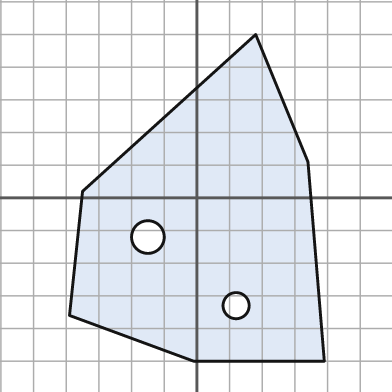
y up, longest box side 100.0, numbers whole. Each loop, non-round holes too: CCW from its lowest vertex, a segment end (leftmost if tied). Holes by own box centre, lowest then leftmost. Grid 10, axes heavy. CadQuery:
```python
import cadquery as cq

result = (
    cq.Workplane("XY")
    .moveTo(-1.0, -50.0)
    .lineTo(39.0, -50.0)
    .lineTo(34.0, 11.0)
    .lineTo(18.0, 50.0)
    .lineTo(-35.0, 2.0)
    .lineTo(-39.0, -36.0)
    .close()
    .moveTo(12.0, -33.0)
    .circle(4.0)
    .moveTo(-15.0, -12.0)
    .circle(5.0)
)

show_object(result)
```